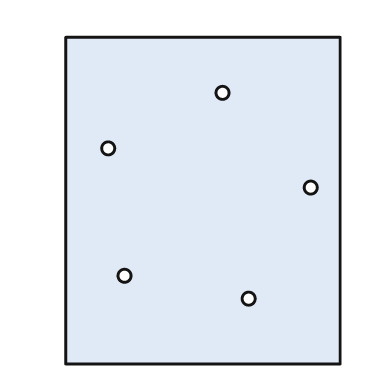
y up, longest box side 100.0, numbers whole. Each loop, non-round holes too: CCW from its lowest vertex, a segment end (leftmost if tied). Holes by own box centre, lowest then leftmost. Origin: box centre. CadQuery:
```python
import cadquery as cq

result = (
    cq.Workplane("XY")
    .moveTo(-42.0, -50.0)
    .lineTo(42.0, -50.0)
    .lineTo(42.0, 50.0)
    .lineTo(-42.0, 50.0)
    .close()
    .moveTo(14.0, -30.0)
    .circle(2.0)
    .moveTo(-24.0, -23.0)
    .circle(2.0)
    .moveTo(33.0, 4.0)
    .circle(2.0)
    .moveTo(-29.0, 16.0)
    .circle(2.0)
    .moveTo(6.0, 33.0)
    .circle(2.0)
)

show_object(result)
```